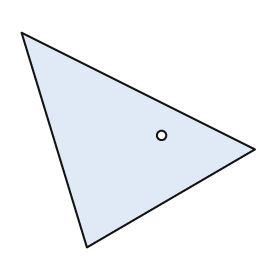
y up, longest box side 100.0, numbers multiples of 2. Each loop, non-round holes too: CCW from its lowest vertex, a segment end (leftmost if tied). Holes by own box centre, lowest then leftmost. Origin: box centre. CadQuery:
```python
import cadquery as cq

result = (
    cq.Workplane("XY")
    .moveTo(-22.0, -46.0)
    .lineTo(50.0, -4.0)
    .lineTo(-50.0, 46.0)
    .close()
    .moveTo(10.0, 2.0)
    .circle(2.0)
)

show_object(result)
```